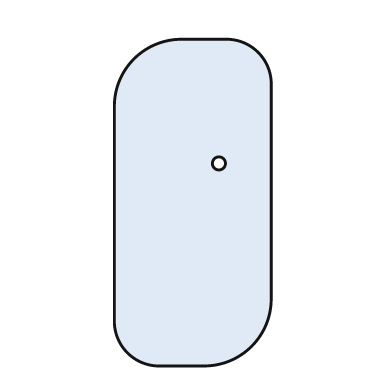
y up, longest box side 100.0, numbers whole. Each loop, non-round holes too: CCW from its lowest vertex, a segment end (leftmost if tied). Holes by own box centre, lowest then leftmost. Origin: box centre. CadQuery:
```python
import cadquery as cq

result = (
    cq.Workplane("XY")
    .moveTo(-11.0, -50.0)
    .lineTo(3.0, -50.0)
    .threePointArc((18.0, -44.0), (24.0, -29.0))
    .lineTo(24.0, 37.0)
    .threePointArc((20.0, 46.0), (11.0, 50.0))
    .lineTo(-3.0, 50.0)
    .threePointArc((-18.0, 44.0), (-24.0, 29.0))
    .lineTo(-24.0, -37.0)
    .threePointArc((-20.0, -46.0), (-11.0, -50.0))
    .close()
    .moveTo(8.0, 12.0)
    .circle(2.0)
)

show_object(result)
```